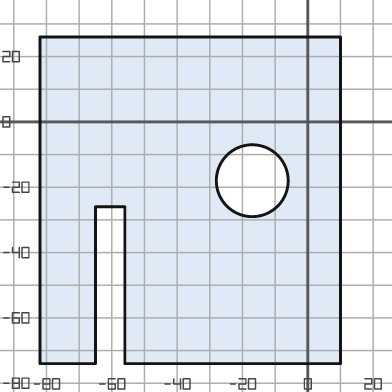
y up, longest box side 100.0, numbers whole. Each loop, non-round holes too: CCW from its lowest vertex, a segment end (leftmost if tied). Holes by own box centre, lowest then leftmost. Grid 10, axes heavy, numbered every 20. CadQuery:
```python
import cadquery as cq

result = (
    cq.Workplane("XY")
    .moveTo(-82.0, -74.0)
    .lineTo(-65.0, -74.0)
    .lineTo(-65.0, -26.0)
    .lineTo(-56.0, -26.0)
    .lineTo(-56.0, -74.0)
    .lineTo(10.0, -74.0)
    .lineTo(10.0, 26.0)
    .lineTo(-82.0, 26.0)
    .close()
    .moveTo(-17.0, -18.0)
    .circle(11.0)
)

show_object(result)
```